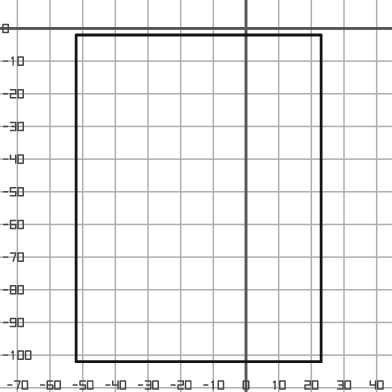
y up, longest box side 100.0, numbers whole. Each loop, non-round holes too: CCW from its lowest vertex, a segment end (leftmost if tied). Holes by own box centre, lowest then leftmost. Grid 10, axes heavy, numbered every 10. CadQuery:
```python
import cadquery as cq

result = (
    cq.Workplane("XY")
    .moveTo(-52.0, -102.0)
    .lineTo(23.0, -102.0)
    .lineTo(23.0, -2.0)
    .lineTo(-52.0, -2.0)
    .close()
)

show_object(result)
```